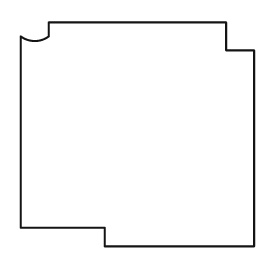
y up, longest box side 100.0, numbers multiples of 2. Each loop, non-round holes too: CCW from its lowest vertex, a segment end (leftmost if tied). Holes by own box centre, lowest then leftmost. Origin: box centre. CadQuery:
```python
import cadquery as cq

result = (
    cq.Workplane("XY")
    .moveTo(-14.0, -48.0)
    .lineTo(50.0, -48.0)
    .lineTo(50.0, 36.0)
    .lineTo(38.0, 36.0)
    .lineTo(38.0, 48.0)
    .lineTo(-38.0, 48.0)
    .lineTo(-38.0, 42.0)
    .threePointArc((-44.0, 40.0), (-50.0, 42.0))
    .lineTo(-50.0, -40.0)
    .lineTo(-14.0, -40.0)
    .close()
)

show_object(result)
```